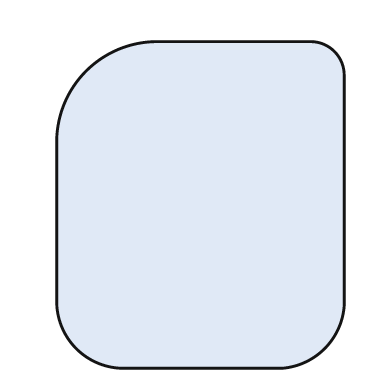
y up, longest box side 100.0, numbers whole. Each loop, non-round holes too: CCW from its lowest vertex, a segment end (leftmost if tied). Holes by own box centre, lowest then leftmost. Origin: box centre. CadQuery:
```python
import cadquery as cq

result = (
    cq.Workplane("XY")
    .moveTo(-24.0, -50.0)
    .lineTo(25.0, -50.0)
    .threePointArc((38.0, -44.0), (44.0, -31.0))
    .lineTo(44.0, 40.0)
    .threePointArc((41.0, 47.0), (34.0, 50.0))
    .lineTo(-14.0, 50.0)
    .threePointArc((-35.0, 41.0), (-44.0, 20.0))
    .lineTo(-44.0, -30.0)
    .threePointArc((-38.0, -44.0), (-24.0, -50.0))
    .close()
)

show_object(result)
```